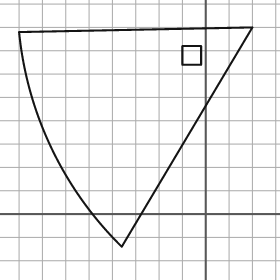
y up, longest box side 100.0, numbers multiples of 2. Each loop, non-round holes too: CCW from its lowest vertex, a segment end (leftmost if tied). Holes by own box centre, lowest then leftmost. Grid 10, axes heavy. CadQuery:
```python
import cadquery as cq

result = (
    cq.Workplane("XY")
    .moveTo(-36.0, -14.0)
    .lineTo(20.0, 80.0)
    .lineTo(-80.0, 78.0)
    .threePointArc((-66.0, 28.0), (-36.0, -14.0))
    .close()
    .moveTo(-10.0, 64.0)
    .lineTo(-2.0, 64.0)
    .lineTo(-2.0, 72.0)
    .lineTo(-10.0, 72.0)
    .close()
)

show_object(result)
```